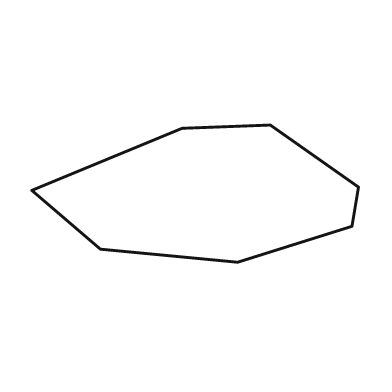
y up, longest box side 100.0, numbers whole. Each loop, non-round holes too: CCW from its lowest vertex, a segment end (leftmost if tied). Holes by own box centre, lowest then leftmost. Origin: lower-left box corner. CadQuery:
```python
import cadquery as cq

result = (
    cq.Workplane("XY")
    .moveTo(63.0, 0.0)
    .lineTo(98.0, 11.0)
    .lineTo(100.0, 23.0)
    .lineTo(73.0, 42.0)
    .lineTo(46.0, 41.0)
    .lineTo(0.0, 22.0)
    .lineTo(21.0, 4.0)
    .close()
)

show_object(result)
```